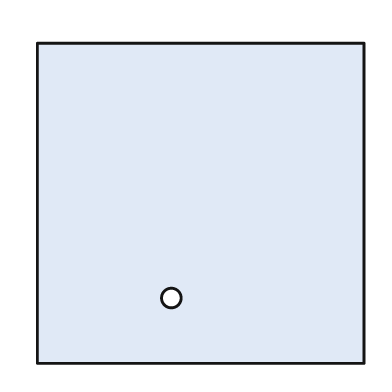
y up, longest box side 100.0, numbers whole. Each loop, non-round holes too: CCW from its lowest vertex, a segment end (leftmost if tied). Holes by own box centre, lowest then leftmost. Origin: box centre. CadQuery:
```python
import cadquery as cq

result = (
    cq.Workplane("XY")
    .moveTo(-50.0, -49.0)
    .lineTo(50.0, -49.0)
    .lineTo(50.0, 49.0)
    .lineTo(-50.0, 49.0)
    .close()
    .moveTo(-9.0, -29.0)
    .circle(3.0)
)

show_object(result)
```